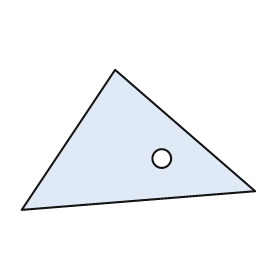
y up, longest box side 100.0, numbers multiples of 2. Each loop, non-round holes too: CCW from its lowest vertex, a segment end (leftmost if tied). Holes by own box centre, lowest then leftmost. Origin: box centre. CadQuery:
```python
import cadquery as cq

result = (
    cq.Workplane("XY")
    .moveTo(-50.0, -30.0)
    .lineTo(50.0, -22.0)
    .lineTo(-10.0, 30.0)
    .close()
    .moveTo(10.0, -8.0)
    .circle(4.0)
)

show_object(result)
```